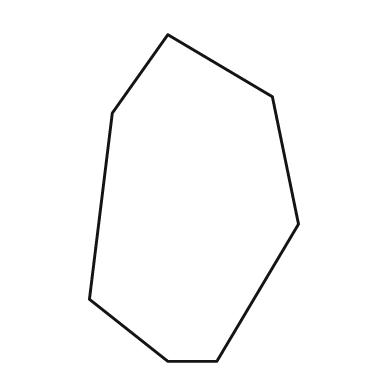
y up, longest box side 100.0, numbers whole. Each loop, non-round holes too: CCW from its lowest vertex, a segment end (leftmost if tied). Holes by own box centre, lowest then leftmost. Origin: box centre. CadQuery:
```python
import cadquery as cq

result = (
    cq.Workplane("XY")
    .moveTo(-8.0, -50.0)
    .lineTo(7.0, -50.0)
    .lineTo(32.0, -8.0)
    .lineTo(24.0, 31.0)
    .lineTo(-8.0, 50.0)
    .lineTo(-25.0, 26.0)
    .lineTo(-32.0, -31.0)
    .close()
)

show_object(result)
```